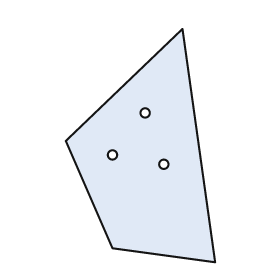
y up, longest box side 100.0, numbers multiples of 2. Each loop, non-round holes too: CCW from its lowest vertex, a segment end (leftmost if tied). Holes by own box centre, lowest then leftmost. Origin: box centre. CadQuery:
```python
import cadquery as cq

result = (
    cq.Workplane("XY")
    .moveTo(32.0, -50.0)
    .lineTo(18.0, 50.0)
    .lineTo(-32.0, 2.0)
    .lineTo(-12.0, -44.0)
    .close()
    .moveTo(10.0, -8.0)
    .circle(2.0)
    .moveTo(-12.0, -4.0)
    .circle(2.0)
    .moveTo(2.0, 14.0)
    .circle(2.0)
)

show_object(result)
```